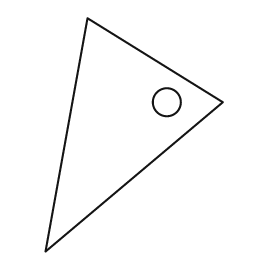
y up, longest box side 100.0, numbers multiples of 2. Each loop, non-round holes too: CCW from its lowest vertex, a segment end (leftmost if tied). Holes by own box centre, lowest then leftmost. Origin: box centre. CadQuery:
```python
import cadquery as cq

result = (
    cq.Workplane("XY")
    .moveTo(-38.0, -50.0)
    .lineTo(38.0, 14.0)
    .lineTo(-20.0, 50.0)
    .close()
    .moveTo(14.0, 14.0)
    .circle(6.0)
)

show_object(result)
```